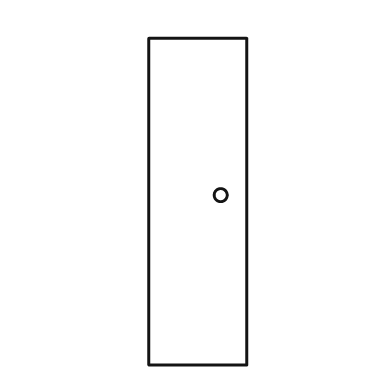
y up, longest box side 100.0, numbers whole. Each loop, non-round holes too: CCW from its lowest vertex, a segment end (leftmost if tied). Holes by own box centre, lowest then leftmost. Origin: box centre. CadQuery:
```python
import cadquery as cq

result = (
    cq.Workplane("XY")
    .moveTo(-15.0, -50.0)
    .lineTo(15.0, -50.0)
    .lineTo(15.0, 50.0)
    .lineTo(-15.0, 50.0)
    .close()
    .moveTo(7.0, 2.0)
    .circle(2.0)
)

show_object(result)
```